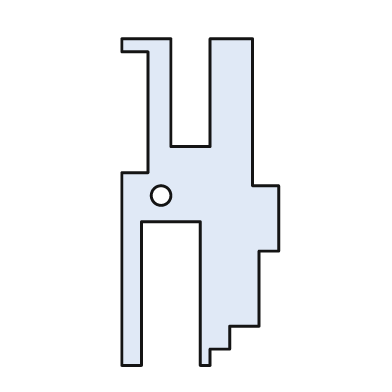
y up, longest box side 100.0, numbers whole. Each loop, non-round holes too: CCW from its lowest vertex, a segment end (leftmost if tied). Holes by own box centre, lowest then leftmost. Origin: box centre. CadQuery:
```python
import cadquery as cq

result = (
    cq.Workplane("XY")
    .moveTo(-24.0, -50.0)
    .lineTo(-18.0, -50.0)
    .lineTo(-18.0, -6.0)
    .lineTo(0.0, -6.0)
    .lineTo(0.0, -50.0)
    .lineTo(3.0, -50.0)
    .lineTo(3.0, -45.0)
    .lineTo(9.0, -45.0)
    .lineTo(9.0, -38.0)
    .lineTo(18.0, -38.0)
    .lineTo(18.0, -15.0)
    .lineTo(24.0, -15.0)
    .lineTo(24.0, 5.0)
    .lineTo(16.0, 5.0)
    .lineTo(16.0, 50.0)
    .lineTo(3.0, 50.0)
    .lineTo(3.0, 17.0)
    .lineTo(-9.0, 17.0)
    .lineTo(-9.0, 50.0)
    .lineTo(-24.0, 50.0)
    .lineTo(-24.0, 46.0)
    .lineTo(-16.0, 46.0)
    .lineTo(-16.0, 9.0)
    .lineTo(-24.0, 9.0)
    .close()
    .moveTo(-12.0, 2.0)
    .circle(3.0)
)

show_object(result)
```